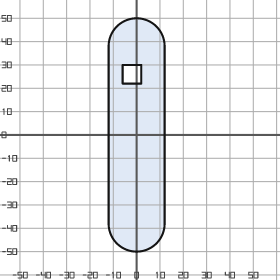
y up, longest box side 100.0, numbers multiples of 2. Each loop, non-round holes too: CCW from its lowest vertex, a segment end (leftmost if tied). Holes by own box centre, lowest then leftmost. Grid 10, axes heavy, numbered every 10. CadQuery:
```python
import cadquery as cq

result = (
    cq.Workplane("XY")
    .moveTo(-12.0, -38.0)
    .threePointArc((0.0, -50.0), (12.0, -38.0))
    .lineTo(12.0, 38.0)
    .threePointArc((0.0, 50.0), (-12.0, 38.0))
    .close()
    .moveTo(-6.0, 22.0)
    .lineTo(2.0, 22.0)
    .lineTo(2.0, 30.0)
    .lineTo(-6.0, 30.0)
    .close()
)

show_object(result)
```